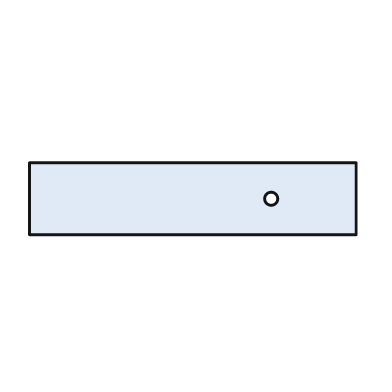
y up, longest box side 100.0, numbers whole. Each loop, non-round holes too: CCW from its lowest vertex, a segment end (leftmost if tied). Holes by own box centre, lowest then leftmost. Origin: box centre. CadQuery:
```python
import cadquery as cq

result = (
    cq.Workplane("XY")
    .moveTo(-50.0, -11.0)
    .lineTo(50.0, -11.0)
    .lineTo(50.0, 11.0)
    .lineTo(-50.0, 11.0)
    .close()
    .moveTo(24.0, 0.0)
    .circle(2.0)
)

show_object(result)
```